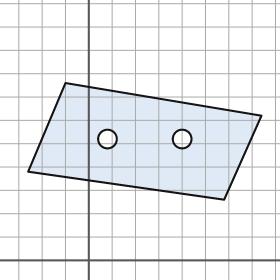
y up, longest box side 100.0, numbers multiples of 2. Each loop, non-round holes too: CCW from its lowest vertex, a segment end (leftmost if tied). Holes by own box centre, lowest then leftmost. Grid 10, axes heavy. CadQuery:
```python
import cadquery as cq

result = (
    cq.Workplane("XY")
    .moveTo(58.0, 26.0)
    .lineTo(74.0, 62.0)
    .lineTo(-10.0, 76.0)
    .lineTo(-26.0, 38.0)
    .close()
    .moveTo(8.0, 52.0)
    .circle(4.0)
    .moveTo(40.0, 52.0)
    .circle(4.0)
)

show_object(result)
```